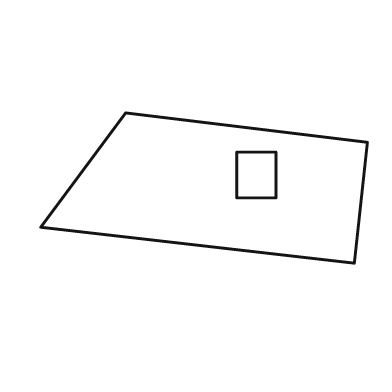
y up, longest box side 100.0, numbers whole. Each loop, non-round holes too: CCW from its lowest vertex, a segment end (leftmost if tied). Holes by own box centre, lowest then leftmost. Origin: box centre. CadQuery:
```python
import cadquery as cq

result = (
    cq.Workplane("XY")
    .moveTo(46.0, -23.0)
    .lineTo(50.0, 14.0)
    .lineTo(-24.0, 23.0)
    .lineTo(-50.0, -12.0)
    .close()
    .moveTo(10.0, -3.0)
    .lineTo(22.0, -3.0)
    .lineTo(22.0, 11.0)
    .lineTo(10.0, 11.0)
    .close()
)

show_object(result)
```